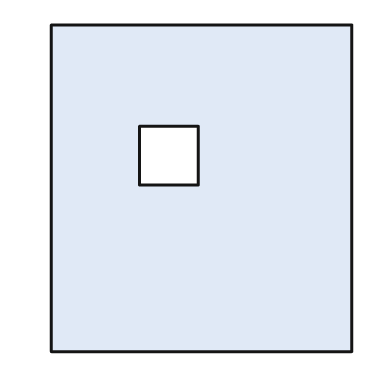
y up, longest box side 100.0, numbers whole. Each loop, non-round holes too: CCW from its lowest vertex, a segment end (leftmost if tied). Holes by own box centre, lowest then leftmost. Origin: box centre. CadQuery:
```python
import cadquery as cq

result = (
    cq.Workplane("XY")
    .moveTo(-46.0, -50.0)
    .lineTo(46.0, -50.0)
    .lineTo(46.0, 50.0)
    .lineTo(-46.0, 50.0)
    .close()
    .moveTo(-19.0, 1.0)
    .lineTo(-1.0, 1.0)
    .lineTo(-1.0, 19.0)
    .lineTo(-19.0, 19.0)
    .close()
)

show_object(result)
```